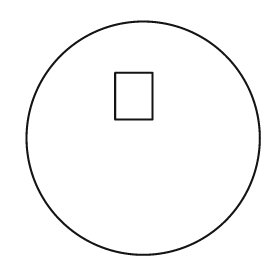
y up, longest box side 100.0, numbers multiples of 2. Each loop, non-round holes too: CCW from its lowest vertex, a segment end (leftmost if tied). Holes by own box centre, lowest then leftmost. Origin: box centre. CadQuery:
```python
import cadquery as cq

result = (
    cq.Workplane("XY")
    .moveTo(0.0, 0.0)
    .circle(50.0)
    .moveTo(-12.0, 8.0)
    .lineTo(4.0, 8.0)
    .lineTo(4.0, 28.0)
    .lineTo(-12.0, 28.0)
    .close()
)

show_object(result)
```